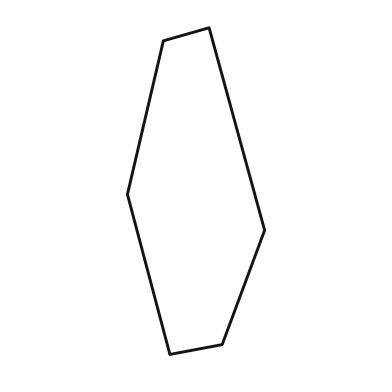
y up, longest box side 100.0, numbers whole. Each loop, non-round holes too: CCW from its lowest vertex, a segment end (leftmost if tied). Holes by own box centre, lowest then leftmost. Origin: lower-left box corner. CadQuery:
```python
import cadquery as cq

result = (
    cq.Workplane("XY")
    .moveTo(13.0, 0.0)
    .lineTo(29.0, 3.0)
    .lineTo(42.0, 38.0)
    .lineTo(25.0, 100.0)
    .lineTo(11.0, 96.0)
    .lineTo(0.0, 49.0)
    .close()
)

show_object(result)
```